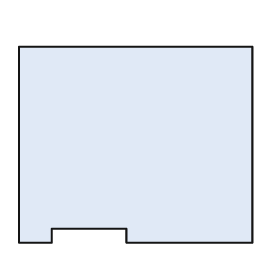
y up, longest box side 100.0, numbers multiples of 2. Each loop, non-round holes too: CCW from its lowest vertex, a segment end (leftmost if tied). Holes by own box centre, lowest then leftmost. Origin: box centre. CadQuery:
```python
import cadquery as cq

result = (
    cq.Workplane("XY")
    .moveTo(-50.0, -42.0)
    .lineTo(-36.0, -42.0)
    .lineTo(-36.0, -36.0)
    .lineTo(-4.0, -36.0)
    .lineTo(-4.0, -42.0)
    .lineTo(50.0, -42.0)
    .lineTo(50.0, 42.0)
    .lineTo(-50.0, 42.0)
    .close()
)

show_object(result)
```